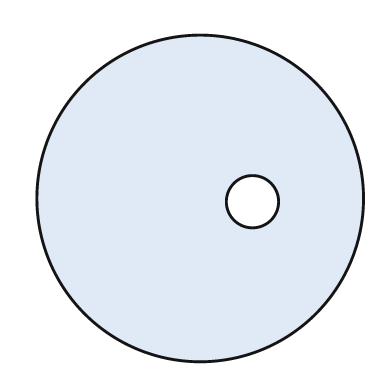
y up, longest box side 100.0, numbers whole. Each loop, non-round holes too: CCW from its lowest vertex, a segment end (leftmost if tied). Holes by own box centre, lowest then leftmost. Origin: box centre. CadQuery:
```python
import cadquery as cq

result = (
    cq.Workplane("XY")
    .moveTo(0.0, 0.0)
    .circle(50.0)
    .moveTo(16.0, -1.0)
    .circle(8.0)
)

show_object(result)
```